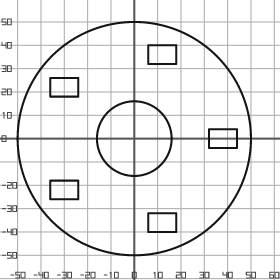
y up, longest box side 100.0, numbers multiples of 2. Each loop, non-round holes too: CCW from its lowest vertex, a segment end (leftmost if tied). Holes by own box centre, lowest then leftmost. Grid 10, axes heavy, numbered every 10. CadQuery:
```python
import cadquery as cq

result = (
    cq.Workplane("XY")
    .moveTo(0.0, 0.0)
    .circle(50.0)
    .moveTo(6.0, -40.0)
    .lineTo(18.0, -40.0)
    .lineTo(18.0, -32.0)
    .lineTo(6.0, -32.0)
    .close()
    .moveTo(-36.0, -26.0)
    .lineTo(-24.0, -26.0)
    .lineTo(-24.0, -18.0)
    .lineTo(-36.0, -18.0)
    .close()
    .moveTo(0.0, 0.0)
    .circle(16.0)
    .moveTo(32.0, -4.0)
    .lineTo(44.0, -4.0)
    .lineTo(44.0, 4.0)
    .lineTo(32.0, 4.0)
    .close()
    .moveTo(-36.0, 18.0)
    .lineTo(-24.0, 18.0)
    .lineTo(-24.0, 26.0)
    .lineTo(-36.0, 26.0)
    .close()
    .moveTo(6.0, 32.0)
    .lineTo(18.0, 32.0)
    .lineTo(18.0, 40.0)
    .lineTo(6.0, 40.0)
    .close()
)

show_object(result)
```